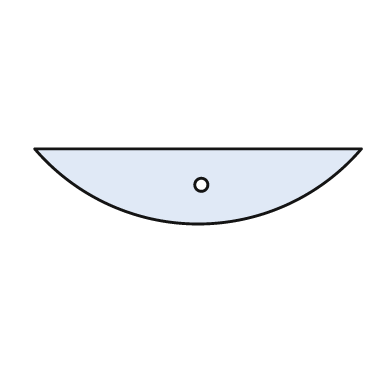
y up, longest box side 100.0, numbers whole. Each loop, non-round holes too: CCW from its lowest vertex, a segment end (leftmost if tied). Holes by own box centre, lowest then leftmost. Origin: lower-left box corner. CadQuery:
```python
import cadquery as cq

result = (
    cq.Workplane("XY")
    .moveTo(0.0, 23.0)
    .threePointArc((50.0, 0.0), (100.0, 23.0))
    .close()
    .moveTo(51.0, 12.0)
    .circle(2.0)
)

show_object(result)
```